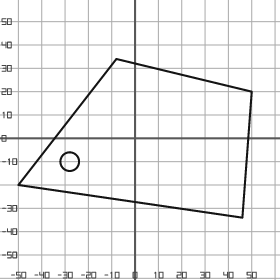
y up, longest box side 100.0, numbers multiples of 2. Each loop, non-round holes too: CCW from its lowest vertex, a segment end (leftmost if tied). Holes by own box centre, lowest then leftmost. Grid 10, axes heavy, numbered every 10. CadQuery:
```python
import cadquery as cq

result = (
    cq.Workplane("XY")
    .moveTo(46.0, -34.0)
    .lineTo(50.0, 20.0)
    .lineTo(-8.0, 34.0)
    .lineTo(-50.0, -20.0)
    .close()
    .moveTo(-28.0, -10.0)
    .circle(4.0)
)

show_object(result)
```